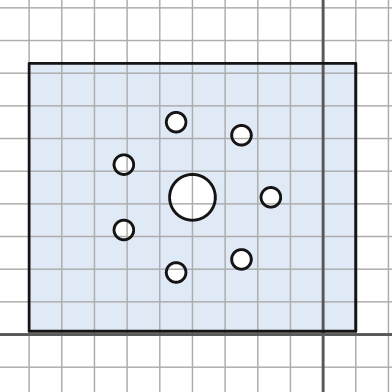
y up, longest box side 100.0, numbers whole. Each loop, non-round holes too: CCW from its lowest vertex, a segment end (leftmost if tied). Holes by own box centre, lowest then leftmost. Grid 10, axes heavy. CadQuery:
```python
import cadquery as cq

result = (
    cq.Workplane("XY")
    .moveTo(-90.0, 1.0)
    .lineTo(10.0, 1.0)
    .lineTo(10.0, 83.0)
    .lineTo(-90.0, 83.0)
    .close()
    .moveTo(-45.0, 19.0)
    .circle(3.0)
    .moveTo(-25.0, 23.0)
    .circle(3.0)
    .moveTo(-61.0, 32.0)
    .circle(3.0)
    .moveTo(-40.0, 42.0)
    .circle(7.0)
    .moveTo(-16.0, 42.0)
    .circle(3.0)
    .moveTo(-61.0, 52.0)
    .circle(3.0)
    .moveTo(-25.0, 61.0)
    .circle(3.0)
    .moveTo(-45.0, 65.0)
    .circle(3.0)
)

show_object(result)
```